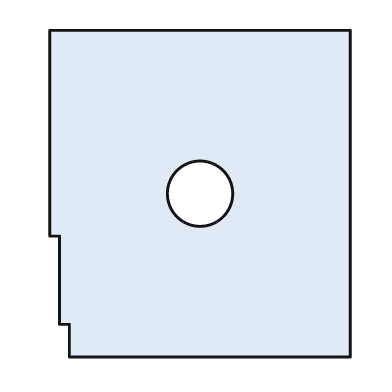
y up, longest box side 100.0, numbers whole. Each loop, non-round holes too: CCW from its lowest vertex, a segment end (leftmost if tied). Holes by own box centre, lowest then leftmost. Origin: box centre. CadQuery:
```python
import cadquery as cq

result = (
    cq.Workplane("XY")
    .moveTo(-40.0, -50.0)
    .lineTo(46.0, -50.0)
    .lineTo(46.0, 50.0)
    .lineTo(-46.0, 50.0)
    .lineTo(-46.0, -13.0)
    .lineTo(-43.0, -13.0)
    .lineTo(-43.0, -40.0)
    .lineTo(-40.0, -40.0)
    .close()
    .moveTo(0.0, 0.0)
    .circle(10.0)
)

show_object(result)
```